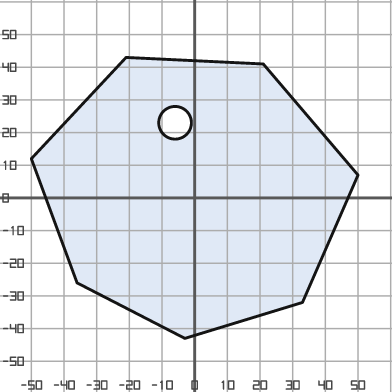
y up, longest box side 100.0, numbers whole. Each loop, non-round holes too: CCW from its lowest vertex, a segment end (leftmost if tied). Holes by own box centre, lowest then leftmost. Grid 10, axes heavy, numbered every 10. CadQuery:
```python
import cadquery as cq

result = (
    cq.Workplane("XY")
    .moveTo(-3.0, -43.0)
    .lineTo(33.0, -32.0)
    .lineTo(50.0, 7.0)
    .lineTo(21.0, 41.0)
    .lineTo(-21.0, 43.0)
    .lineTo(-50.0, 12.0)
    .lineTo(-36.0, -26.0)
    .close()
    .moveTo(-6.0, 23.0)
    .circle(5.0)
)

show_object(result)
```